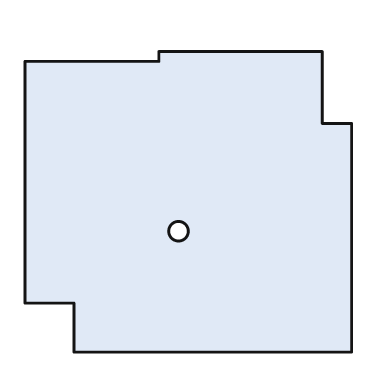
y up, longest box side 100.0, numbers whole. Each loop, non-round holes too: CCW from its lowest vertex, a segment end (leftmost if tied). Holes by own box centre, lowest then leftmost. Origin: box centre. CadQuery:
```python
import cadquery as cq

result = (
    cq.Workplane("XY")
    .moveTo(-35.0, -46.0)
    .lineTo(50.0, -46.0)
    .lineTo(50.0, 24.0)
    .lineTo(41.0, 24.0)
    .lineTo(41.0, 46.0)
    .lineTo(-9.0, 46.0)
    .lineTo(-9.0, 43.0)
    .lineTo(-50.0, 43.0)
    .lineTo(-50.0, -31.0)
    .lineTo(-35.0, -31.0)
    .close()
    .moveTo(-3.0, -9.0)
    .circle(3.0)
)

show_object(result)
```